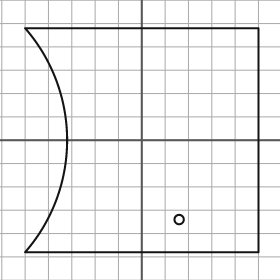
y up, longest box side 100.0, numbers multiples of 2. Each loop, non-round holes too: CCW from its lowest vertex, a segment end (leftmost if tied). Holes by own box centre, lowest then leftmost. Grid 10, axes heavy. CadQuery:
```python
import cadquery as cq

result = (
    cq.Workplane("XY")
    .moveTo(-50.0, -48.0)
    .lineTo(50.0, -48.0)
    .lineTo(50.0, 48.0)
    .lineTo(-50.0, 48.0)
    .threePointArc((-32.0, 0.0), (-50.0, -48.0))
    .close()
    .moveTo(16.0, -34.0)
    .circle(2.0)
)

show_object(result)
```